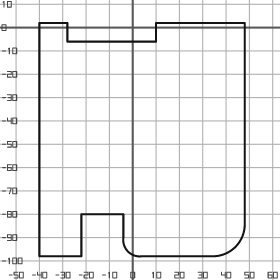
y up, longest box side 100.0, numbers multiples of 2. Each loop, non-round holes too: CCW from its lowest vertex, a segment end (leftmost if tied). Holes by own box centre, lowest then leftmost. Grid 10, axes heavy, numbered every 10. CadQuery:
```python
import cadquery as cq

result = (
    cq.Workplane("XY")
    .moveTo(-40.0, -98.0)
    .lineTo(-22.0, -98.0)
    .lineTo(-22.0, -80.0)
    .lineTo(-4.0, -80.0)
    .lineTo(-4.0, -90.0)
    .threePointArc((-2.0, -96.0), (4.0, -98.0))
    .lineTo(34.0, -98.0)
    .threePointArc((44.0, -94.0), (48.0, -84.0))
    .lineTo(48.0, 2.0)
    .lineTo(10.0, 2.0)
    .lineTo(10.0, -6.0)
    .lineTo(-28.0, -6.0)
    .lineTo(-28.0, 2.0)
    .lineTo(-40.0, 2.0)
    .close()
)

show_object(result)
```